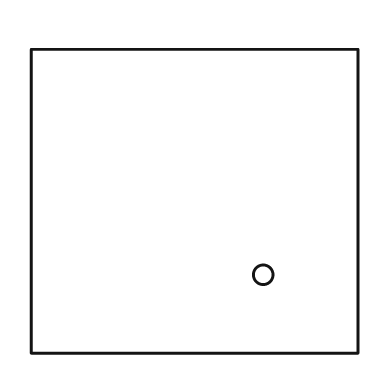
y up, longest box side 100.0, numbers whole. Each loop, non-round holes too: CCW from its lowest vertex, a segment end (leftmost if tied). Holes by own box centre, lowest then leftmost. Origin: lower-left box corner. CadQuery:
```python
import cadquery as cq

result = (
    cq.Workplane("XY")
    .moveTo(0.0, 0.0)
    .lineTo(100.0, 0.0)
    .lineTo(100.0, 93.0)
    .lineTo(0.0, 93.0)
    .close()
    .moveTo(71.0, 24.0)
    .circle(3.0)
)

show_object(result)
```